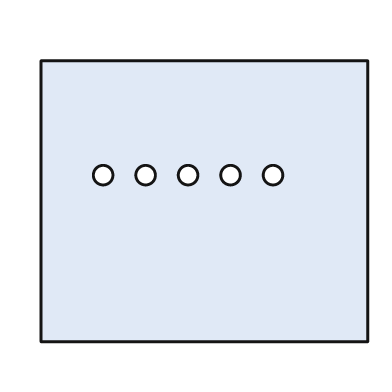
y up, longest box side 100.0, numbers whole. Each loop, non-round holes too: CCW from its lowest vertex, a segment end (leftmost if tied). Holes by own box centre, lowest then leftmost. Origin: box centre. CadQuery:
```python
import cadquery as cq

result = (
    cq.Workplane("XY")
    .moveTo(-50.0, -43.0)
    .lineTo(50.0, -43.0)
    .lineTo(50.0, 43.0)
    .lineTo(-50.0, 43.0)
    .close()
    .moveTo(-31.0, 8.0)
    .circle(3.0)
    .moveTo(-18.0, 8.0)
    .circle(3.0)
    .moveTo(-5.0, 8.0)
    .circle(3.0)
    .moveTo(8.0, 8.0)
    .circle(3.0)
    .moveTo(21.0, 8.0)
    .circle(3.0)
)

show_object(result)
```